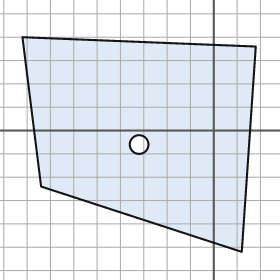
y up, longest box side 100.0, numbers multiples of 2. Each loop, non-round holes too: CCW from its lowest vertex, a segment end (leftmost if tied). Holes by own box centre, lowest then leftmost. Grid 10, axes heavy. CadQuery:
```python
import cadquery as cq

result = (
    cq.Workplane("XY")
    .moveTo(12.0, -52.0)
    .lineTo(18.0, 36.0)
    .lineTo(-82.0, 40.0)
    .lineTo(-74.0, -24.0)
    .close()
    .moveTo(-32.0, -6.0)
    .circle(4.0)
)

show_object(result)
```